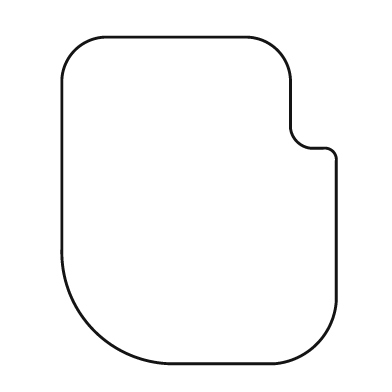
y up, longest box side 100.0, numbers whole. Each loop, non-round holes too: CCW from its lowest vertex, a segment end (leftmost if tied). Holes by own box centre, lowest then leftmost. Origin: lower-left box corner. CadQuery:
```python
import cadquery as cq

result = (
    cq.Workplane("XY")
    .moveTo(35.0, 0.0)
    .lineTo(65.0, 0.0)
    .threePointArc((78.0, 6.0), (84.0, 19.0))
    .lineTo(84.0, 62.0)
    .threePointArc((83.0, 65.0), (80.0, 66.0))
    .lineTo(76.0, 66.0)
    .threePointArc((72.0, 68.0), (70.0, 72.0))
    .lineTo(70.0, 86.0)
    .threePointArc((66.0, 96.0), (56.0, 100.0))
    .lineTo(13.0, 100.0)
    .threePointArc((4.0, 96.0), (0.0, 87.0))
    .lineTo(0.0, 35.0)
    .threePointArc((10.0, 10.0), (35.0, 0.0))
    .close()
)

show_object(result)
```